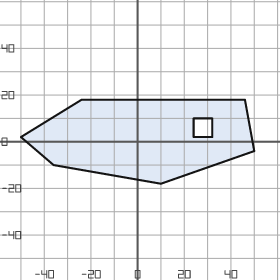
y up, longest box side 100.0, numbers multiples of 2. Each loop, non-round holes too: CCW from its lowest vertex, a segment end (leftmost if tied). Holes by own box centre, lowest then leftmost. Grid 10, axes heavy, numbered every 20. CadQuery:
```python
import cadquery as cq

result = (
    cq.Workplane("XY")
    .moveTo(10.0, -18.0)
    .lineTo(50.0, -4.0)
    .lineTo(46.0, 18.0)
    .lineTo(-24.0, 18.0)
    .lineTo(-50.0, 2.0)
    .lineTo(-36.0, -10.0)
    .close()
    .moveTo(24.0, 2.0)
    .lineTo(32.0, 2.0)
    .lineTo(32.0, 10.0)
    .lineTo(24.0, 10.0)
    .close()
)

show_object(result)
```